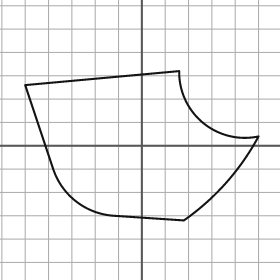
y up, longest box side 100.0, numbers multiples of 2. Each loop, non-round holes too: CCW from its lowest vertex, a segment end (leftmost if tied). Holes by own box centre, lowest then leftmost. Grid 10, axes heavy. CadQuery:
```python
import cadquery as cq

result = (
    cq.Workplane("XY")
    .moveTo(18.0, -32.0)
    .threePointArc((36.0, -16.0), (50.0, 4.0))
    .threePointArc((26.0, 10.0), (16.0, 32.0))
    .lineTo(-50.0, 26.0)
    .lineTo(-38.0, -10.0)
    .threePointArc((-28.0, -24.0), (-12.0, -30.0))
    .close()
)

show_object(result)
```